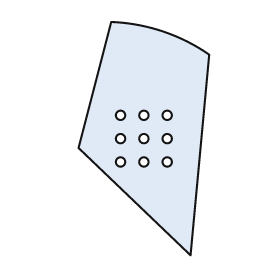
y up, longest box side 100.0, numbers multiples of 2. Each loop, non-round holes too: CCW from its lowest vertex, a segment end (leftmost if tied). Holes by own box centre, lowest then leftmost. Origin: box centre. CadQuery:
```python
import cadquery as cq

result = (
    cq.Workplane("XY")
    .moveTo(20.0, -50.0)
    .lineTo(28.0, 36.0)
    .threePointArc((8.0, 46.0), (-14.0, 50.0))
    .lineTo(-28.0, -4.0)
    .close()
    .moveTo(-10.0, -10.0)
    .circle(2.0)
    .moveTo(0.0, -10.0)
    .circle(2.0)
    .moveTo(10.0, -10.0)
    .circle(2.0)
    .moveTo(-10.0, 0.0)
    .circle(2.0)
    .moveTo(0.0, 0.0)
    .circle(2.0)
    .moveTo(10.0, 0.0)
    .circle(2.0)
    .moveTo(-10.0, 10.0)
    .circle(2.0)
    .moveTo(0.0, 10.0)
    .circle(2.0)
    .moveTo(10.0, 10.0)
    .circle(2.0)
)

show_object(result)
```